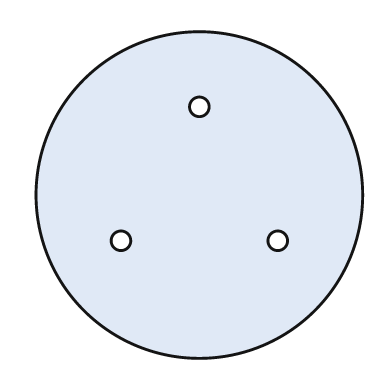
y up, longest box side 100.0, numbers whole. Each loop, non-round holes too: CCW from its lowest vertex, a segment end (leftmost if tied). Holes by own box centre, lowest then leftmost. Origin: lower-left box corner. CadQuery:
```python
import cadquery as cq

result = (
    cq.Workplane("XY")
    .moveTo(50.0, 50.0)
    .circle(50.0)
    .moveTo(26.0, 36.0)
    .circle(3.0)
    .moveTo(74.0, 36.0)
    .circle(3.0)
    .moveTo(50.0, 77.0)
    .circle(3.0)
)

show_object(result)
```